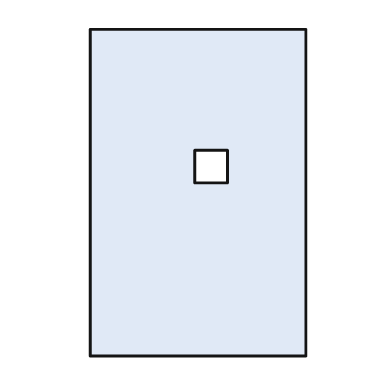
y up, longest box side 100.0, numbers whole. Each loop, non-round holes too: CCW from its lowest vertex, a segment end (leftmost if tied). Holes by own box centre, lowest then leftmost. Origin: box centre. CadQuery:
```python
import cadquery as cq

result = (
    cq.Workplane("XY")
    .moveTo(-33.0, -50.0)
    .lineTo(33.0, -50.0)
    .lineTo(33.0, 50.0)
    .lineTo(-33.0, 50.0)
    .close()
    .moveTo(-1.0, 3.0)
    .lineTo(9.0, 3.0)
    .lineTo(9.0, 13.0)
    .lineTo(-1.0, 13.0)
    .close()
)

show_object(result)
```